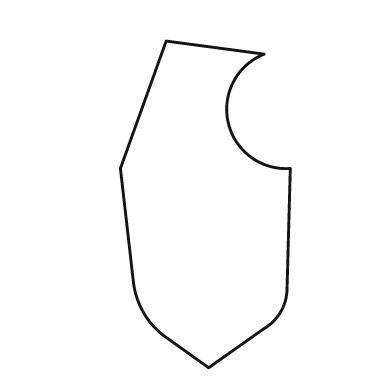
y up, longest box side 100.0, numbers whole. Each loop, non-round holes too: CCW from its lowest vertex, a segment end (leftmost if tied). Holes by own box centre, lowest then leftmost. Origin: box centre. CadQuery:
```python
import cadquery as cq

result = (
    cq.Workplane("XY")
    .moveTo(1.0, -50.0)
    .lineTo(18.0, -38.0)
    .threePointArc((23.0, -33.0), (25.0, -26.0))
    .lineTo(26.0, 11.0)
    .threePointArc((7.0, 25.0), (18.0, 46.0))
    .lineTo(-12.0, 50.0)
    .lineTo(-26.0, 11.0)
    .lineTo(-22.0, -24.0)
    .threePointArc((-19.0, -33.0), (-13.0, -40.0))
    .close()
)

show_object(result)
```